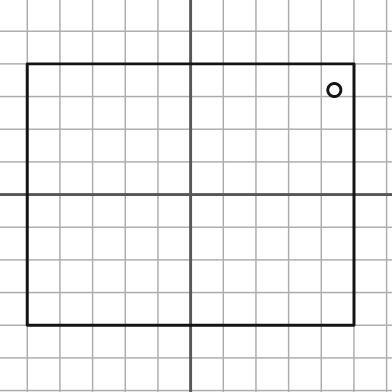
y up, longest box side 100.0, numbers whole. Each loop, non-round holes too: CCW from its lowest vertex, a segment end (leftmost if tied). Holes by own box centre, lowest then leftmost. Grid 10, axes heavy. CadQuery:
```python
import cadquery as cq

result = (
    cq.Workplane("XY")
    .moveTo(-50.0, -40.0)
    .lineTo(50.0, -40.0)
    .lineTo(50.0, 40.0)
    .lineTo(-50.0, 40.0)
    .close()
    .moveTo(44.0, 32.0)
    .circle(2.0)
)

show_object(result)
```